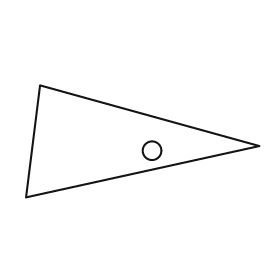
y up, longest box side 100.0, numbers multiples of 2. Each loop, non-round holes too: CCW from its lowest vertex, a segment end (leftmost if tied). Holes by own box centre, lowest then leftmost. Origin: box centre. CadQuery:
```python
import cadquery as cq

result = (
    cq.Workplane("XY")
    .moveTo(-50.0, -24.0)
    .lineTo(50.0, -2.0)
    .lineTo(-44.0, 24.0)
    .close()
    .moveTo(4.0, -4.0)
    .circle(4.0)
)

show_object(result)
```